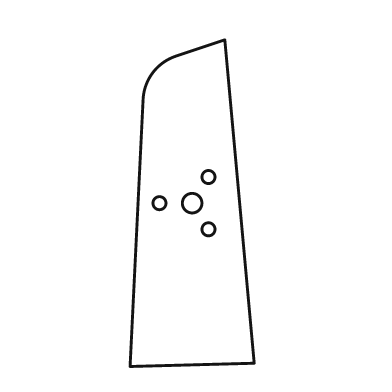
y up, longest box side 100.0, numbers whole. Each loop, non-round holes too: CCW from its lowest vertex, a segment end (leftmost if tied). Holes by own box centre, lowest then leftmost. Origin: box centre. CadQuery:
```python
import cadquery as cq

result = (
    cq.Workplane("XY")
    .moveTo(-19.0, -50.0)
    .lineTo(19.0, -49.0)
    .lineTo(10.0, 50.0)
    .lineTo(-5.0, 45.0)
    .threePointArc((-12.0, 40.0), (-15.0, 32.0))
    .close()
    .moveTo(5.0, -8.0)
    .circle(2.0)
    .moveTo(-10.0, 0.0)
    .circle(2.0)
    .moveTo(0.0, 0.0)
    .circle(3.0)
    .moveTo(5.0, 8.0)
    .circle(2.0)
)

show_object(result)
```